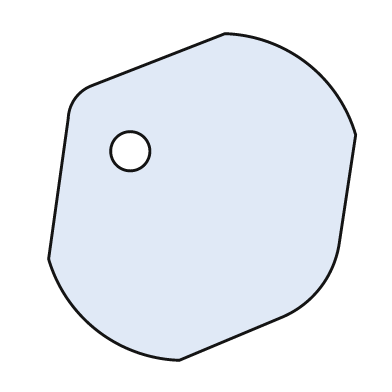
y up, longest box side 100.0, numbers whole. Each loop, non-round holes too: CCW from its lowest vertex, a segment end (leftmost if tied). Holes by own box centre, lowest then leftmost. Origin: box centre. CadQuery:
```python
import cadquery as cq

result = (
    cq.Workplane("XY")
    .moveTo(-7.0, -50.0)
    .lineTo(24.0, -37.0)
    .threePointArc((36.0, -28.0), (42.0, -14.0))
    .lineTo(47.0, 19.0)
    .threePointArc((32.0, 41.0), (7.0, 50.0))
    .lineTo(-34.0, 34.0)
    .threePointArc((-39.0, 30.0), (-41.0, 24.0))
    .lineTo(-47.0, -19.0)
    .threePointArc((-32.0, -41.0), (-7.0, -50.0))
    .close()
    .moveTo(-22.0, 14.0)
    .circle(6.0)
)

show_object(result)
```